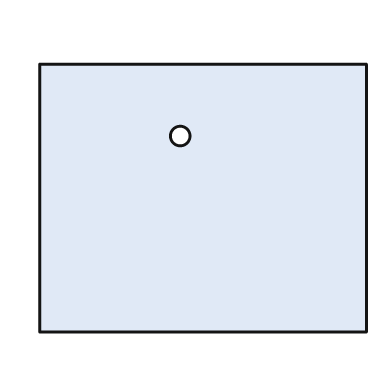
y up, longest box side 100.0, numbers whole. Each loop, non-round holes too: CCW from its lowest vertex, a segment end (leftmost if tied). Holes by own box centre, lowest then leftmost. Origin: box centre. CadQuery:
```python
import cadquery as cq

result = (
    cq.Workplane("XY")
    .moveTo(-50.0, -41.0)
    .lineTo(50.0, -41.0)
    .lineTo(50.0, 41.0)
    .lineTo(-50.0, 41.0)
    .close()
    .moveTo(-7.0, 19.0)
    .circle(3.0)
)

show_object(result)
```